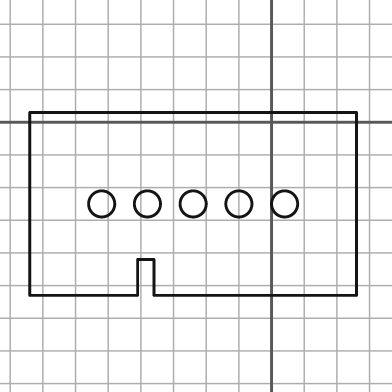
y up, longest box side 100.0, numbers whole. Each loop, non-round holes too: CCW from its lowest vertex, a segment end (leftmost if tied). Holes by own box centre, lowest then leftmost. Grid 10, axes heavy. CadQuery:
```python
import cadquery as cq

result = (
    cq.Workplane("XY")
    .moveTo(-74.0, -53.0)
    .lineTo(-41.0, -53.0)
    .lineTo(-41.0, -42.0)
    .lineTo(-36.0, -42.0)
    .lineTo(-36.0, -53.0)
    .lineTo(26.0, -53.0)
    .lineTo(26.0, 3.0)
    .lineTo(-74.0, 3.0)
    .close()
    .moveTo(-52.0, -25.0)
    .circle(4.0)
    .moveTo(-38.0, -25.0)
    .circle(4.0)
    .moveTo(-24.0, -25.0)
    .circle(4.0)
    .moveTo(-10.0, -25.0)
    .circle(4.0)
    .moveTo(4.0, -25.0)
    .circle(4.0)
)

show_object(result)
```